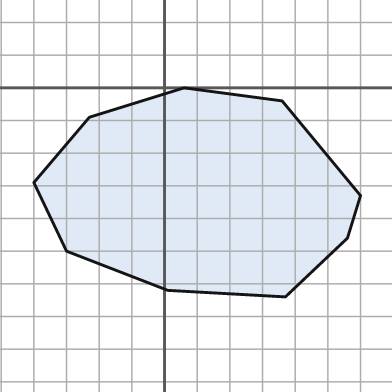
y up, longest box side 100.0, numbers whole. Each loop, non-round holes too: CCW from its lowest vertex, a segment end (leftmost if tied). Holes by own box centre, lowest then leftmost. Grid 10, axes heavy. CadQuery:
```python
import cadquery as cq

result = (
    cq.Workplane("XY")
    .moveTo(37.0, -64.0)
    .lineTo(56.0, -46.0)
    .lineTo(60.0, -33.0)
    .lineTo(36.0, -4.0)
    .lineTo(6.0, 0.0)
    .lineTo(-23.0, -9.0)
    .lineTo(-40.0, -29.0)
    .lineTo(-30.0, -50.0)
    .lineTo(1.0, -62.0)
    .close()
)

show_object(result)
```